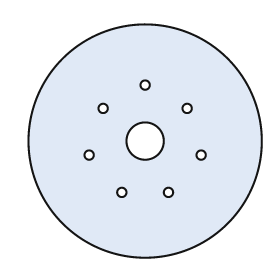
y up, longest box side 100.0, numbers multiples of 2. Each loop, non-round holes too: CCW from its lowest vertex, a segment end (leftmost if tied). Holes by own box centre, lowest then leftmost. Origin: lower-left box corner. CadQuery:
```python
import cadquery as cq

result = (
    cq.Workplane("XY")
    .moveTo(50.0, 50.0)
    .circle(50.0)
    .moveTo(40.0, 28.0)
    .circle(2.0)
    .moveTo(60.0, 28.0)
    .circle(2.0)
    .moveTo(26.0, 44.0)
    .circle(2.0)
    .moveTo(74.0, 44.0)
    .circle(2.0)
    .moveTo(50.0, 50.0)
    .circle(8.0)
    .moveTo(32.0, 64.0)
    .circle(2.0)
    .moveTo(68.0, 64.0)
    .circle(2.0)
    .moveTo(50.0, 74.0)
    .circle(2.0)
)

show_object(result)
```